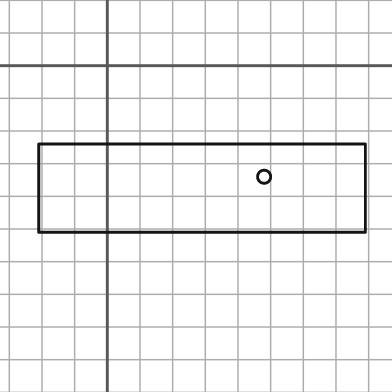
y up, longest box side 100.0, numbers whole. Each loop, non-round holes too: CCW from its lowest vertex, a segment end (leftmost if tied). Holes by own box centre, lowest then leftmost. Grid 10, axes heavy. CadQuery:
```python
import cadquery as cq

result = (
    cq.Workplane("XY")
    .moveTo(-21.0, -51.0)
    .lineTo(79.0, -51.0)
    .lineTo(79.0, -24.0)
    .lineTo(-21.0, -24.0)
    .close()
    .moveTo(48.0, -34.0)
    .circle(2.0)
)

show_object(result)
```